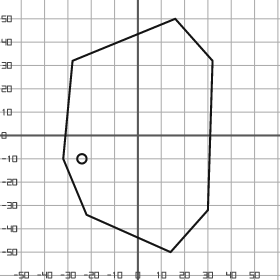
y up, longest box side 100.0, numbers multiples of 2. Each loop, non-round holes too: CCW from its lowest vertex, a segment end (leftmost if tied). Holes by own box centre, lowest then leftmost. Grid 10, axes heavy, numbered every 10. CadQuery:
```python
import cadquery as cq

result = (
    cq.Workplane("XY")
    .moveTo(14.0, -50.0)
    .lineTo(30.0, -32.0)
    .lineTo(32.0, 32.0)
    .lineTo(16.0, 50.0)
    .lineTo(-28.0, 32.0)
    .lineTo(-32.0, -10.0)
    .lineTo(-22.0, -34.0)
    .close()
    .moveTo(-24.0, -10.0)
    .circle(2.0)
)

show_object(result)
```